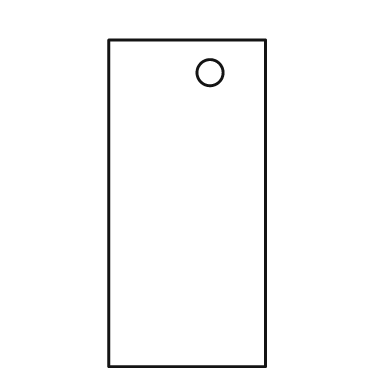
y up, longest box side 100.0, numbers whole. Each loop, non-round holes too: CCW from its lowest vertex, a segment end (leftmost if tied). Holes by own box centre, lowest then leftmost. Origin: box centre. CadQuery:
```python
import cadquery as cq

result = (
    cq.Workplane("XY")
    .moveTo(-24.0, -50.0)
    .lineTo(24.0, -50.0)
    .lineTo(24.0, 50.0)
    .lineTo(-24.0, 50.0)
    .close()
    .moveTo(7.0, 40.0)
    .circle(4.0)
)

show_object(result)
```